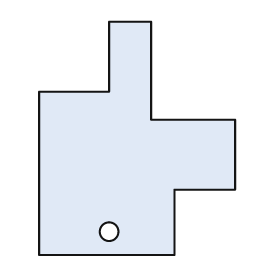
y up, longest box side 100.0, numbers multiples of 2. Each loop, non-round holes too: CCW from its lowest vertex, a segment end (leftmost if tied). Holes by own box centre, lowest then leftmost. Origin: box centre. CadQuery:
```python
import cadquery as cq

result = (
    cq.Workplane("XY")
    .moveTo(-42.0, -50.0)
    .lineTo(16.0, -50.0)
    .lineTo(16.0, -22.0)
    .lineTo(42.0, -22.0)
    .lineTo(42.0, 8.0)
    .lineTo(6.0, 8.0)
    .lineTo(6.0, 50.0)
    .lineTo(-12.0, 50.0)
    .lineTo(-12.0, 20.0)
    .lineTo(-42.0, 20.0)
    .close()
    .moveTo(-12.0, -40.0)
    .circle(4.0)
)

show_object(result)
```